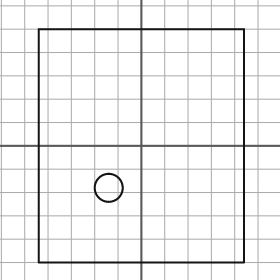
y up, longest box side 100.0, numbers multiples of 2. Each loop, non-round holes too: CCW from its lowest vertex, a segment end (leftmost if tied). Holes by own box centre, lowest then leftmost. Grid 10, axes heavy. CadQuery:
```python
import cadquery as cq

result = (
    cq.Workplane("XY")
    .moveTo(-44.0, -50.0)
    .lineTo(44.0, -50.0)
    .lineTo(44.0, 50.0)
    .lineTo(-44.0, 50.0)
    .close()
    .moveTo(-14.0, -18.0)
    .circle(6.0)
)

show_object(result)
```